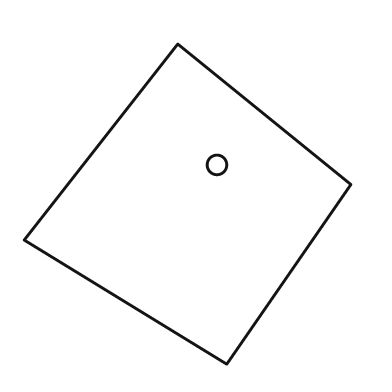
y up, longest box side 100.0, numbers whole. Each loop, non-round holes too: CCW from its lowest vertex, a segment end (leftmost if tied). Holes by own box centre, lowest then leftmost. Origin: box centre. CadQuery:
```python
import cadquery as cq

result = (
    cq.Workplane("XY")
    .moveTo(12.0, -49.0)
    .lineTo(50.0, 6.0)
    .lineTo(-3.0, 49.0)
    .lineTo(-50.0, -11.0)
    .close()
    .moveTo(9.0, 12.0)
    .circle(3.0)
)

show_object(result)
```